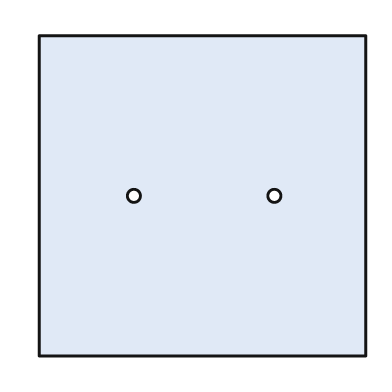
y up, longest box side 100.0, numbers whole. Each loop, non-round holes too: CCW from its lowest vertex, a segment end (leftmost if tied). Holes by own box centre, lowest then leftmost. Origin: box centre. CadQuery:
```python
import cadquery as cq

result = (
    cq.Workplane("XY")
    .moveTo(-50.0, -49.0)
    .lineTo(50.0, -49.0)
    .lineTo(50.0, 49.0)
    .lineTo(-50.0, 49.0)
    .close()
    .moveTo(-21.0, 0.0)
    .circle(2.0)
    .moveTo(22.0, 0.0)
    .circle(2.0)
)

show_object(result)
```